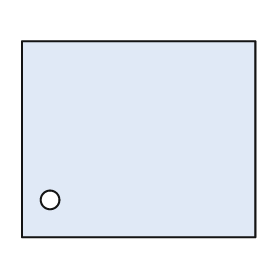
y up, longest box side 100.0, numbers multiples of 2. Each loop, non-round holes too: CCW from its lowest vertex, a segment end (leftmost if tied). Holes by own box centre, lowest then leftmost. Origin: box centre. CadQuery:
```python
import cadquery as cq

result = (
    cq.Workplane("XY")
    .moveTo(-50.0, -42.0)
    .lineTo(50.0, -42.0)
    .lineTo(50.0, 42.0)
    .lineTo(-50.0, 42.0)
    .close()
    .moveTo(-38.0, -26.0)
    .circle(4.0)
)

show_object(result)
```